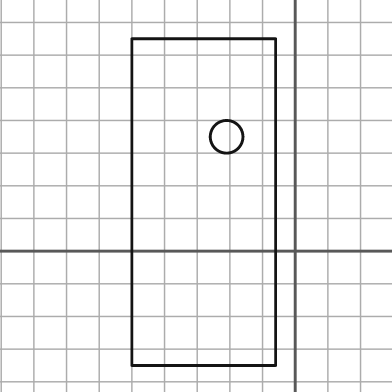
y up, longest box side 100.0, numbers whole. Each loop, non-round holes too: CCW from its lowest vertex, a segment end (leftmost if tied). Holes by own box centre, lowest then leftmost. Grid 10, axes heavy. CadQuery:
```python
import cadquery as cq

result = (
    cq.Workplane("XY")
    .moveTo(-50.0, -35.0)
    .lineTo(-6.0, -35.0)
    .lineTo(-6.0, 65.0)
    .lineTo(-50.0, 65.0)
    .close()
    .moveTo(-21.0, 35.0)
    .circle(5.0)
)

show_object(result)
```